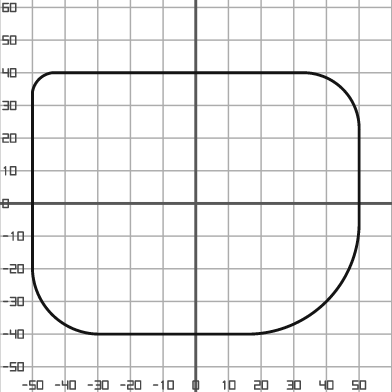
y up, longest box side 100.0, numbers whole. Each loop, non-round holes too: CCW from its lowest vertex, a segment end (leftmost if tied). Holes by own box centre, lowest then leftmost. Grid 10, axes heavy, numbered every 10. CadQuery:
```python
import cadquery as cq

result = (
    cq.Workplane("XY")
    .moveTo(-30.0, -40.0)
    .lineTo(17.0, -40.0)
    .threePointArc((40.0, -30.0), (50.0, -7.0))
    .lineTo(50.0, 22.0)
    .threePointArc((45.0, 35.0), (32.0, 40.0))
    .lineTo(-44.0, 40.0)
    .threePointArc((-48.0, 38.0), (-50.0, 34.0))
    .lineTo(-50.0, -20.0)
    .threePointArc((-44.0, -34.0), (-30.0, -40.0))
    .close()
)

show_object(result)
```